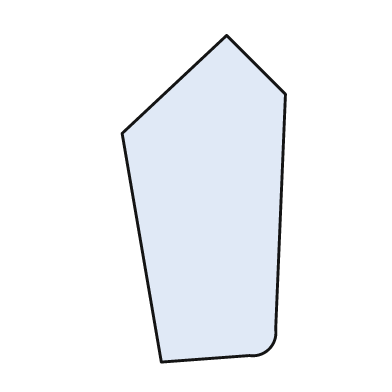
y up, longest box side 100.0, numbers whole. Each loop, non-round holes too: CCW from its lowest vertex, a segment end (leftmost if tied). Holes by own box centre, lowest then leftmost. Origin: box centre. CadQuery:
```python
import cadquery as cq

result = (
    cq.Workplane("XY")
    .moveTo(-13.0, -50.0)
    .lineTo(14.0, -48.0)
    .threePointArc((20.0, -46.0), (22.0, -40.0))
    .lineTo(25.0, 32.0)
    .lineTo(7.0, 50.0)
    .lineTo(-25.0, 20.0)
    .close()
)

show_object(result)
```